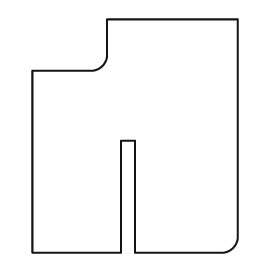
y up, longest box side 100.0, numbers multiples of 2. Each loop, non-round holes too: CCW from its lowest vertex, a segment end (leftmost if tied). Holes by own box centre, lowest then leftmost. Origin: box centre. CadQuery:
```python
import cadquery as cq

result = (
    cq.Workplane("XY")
    .moveTo(-44.0, -50.0)
    .lineTo(-6.0, -50.0)
    .lineTo(-6.0, -2.0)
    .lineTo(0.0, -2.0)
    .lineTo(0.0, -50.0)
    .lineTo(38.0, -50.0)
    .threePointArc((42.0, -48.0), (44.0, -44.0))
    .lineTo(44.0, 50.0)
    .lineTo(-12.0, 50.0)
    .lineTo(-12.0, 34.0)
    .threePointArc((-14.0, 30.0), (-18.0, 28.0))
    .lineTo(-44.0, 28.0)
    .close()
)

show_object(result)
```